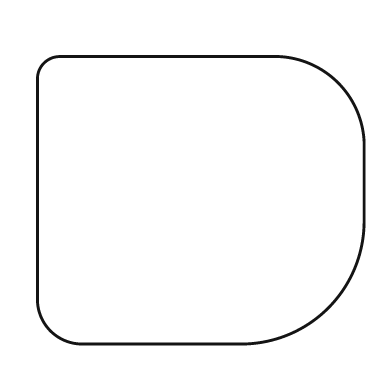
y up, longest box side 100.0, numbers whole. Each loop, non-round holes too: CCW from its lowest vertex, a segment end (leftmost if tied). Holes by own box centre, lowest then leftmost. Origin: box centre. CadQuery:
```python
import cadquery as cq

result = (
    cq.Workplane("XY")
    .moveTo(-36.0, -44.0)
    .lineTo(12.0, -44.0)
    .threePointArc((39.0, -33.0), (50.0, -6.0))
    .lineTo(50.0, 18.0)
    .threePointArc((42.0, 36.0), (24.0, 44.0))
    .lineTo(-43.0, 44.0)
    .threePointArc((-48.0, 42.0), (-50.0, 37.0))
    .lineTo(-50.0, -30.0)
    .threePointArc((-46.0, -40.0), (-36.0, -44.0))
    .close()
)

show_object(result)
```